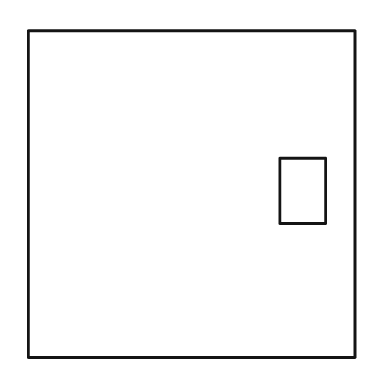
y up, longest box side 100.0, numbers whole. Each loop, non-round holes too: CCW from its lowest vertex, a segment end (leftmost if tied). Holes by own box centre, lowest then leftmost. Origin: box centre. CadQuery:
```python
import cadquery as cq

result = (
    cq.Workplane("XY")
    .moveTo(-50.0, -50.0)
    .lineTo(50.0, -50.0)
    .lineTo(50.0, 50.0)
    .lineTo(-50.0, 50.0)
    .close()
    .moveTo(27.0, -9.0)
    .lineTo(41.0, -9.0)
    .lineTo(41.0, 11.0)
    .lineTo(27.0, 11.0)
    .close()
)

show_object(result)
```